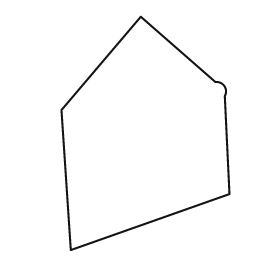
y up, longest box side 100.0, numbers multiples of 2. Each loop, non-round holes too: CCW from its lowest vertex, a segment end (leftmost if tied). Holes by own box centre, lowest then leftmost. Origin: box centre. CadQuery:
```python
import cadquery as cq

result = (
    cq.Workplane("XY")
    .moveTo(-32.0, -50.0)
    .lineTo(36.0, -26.0)
    .lineTo(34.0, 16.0)
    .threePointArc((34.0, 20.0), (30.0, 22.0))
    .lineTo(-2.0, 50.0)
    .lineTo(-36.0, 10.0)
    .close()
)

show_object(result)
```